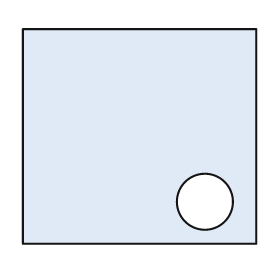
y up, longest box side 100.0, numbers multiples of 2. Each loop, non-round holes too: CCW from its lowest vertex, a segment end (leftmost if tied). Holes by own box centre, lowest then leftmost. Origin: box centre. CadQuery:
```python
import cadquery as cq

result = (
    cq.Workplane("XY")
    .moveTo(-50.0, -46.0)
    .lineTo(50.0, -46.0)
    .lineTo(50.0, 46.0)
    .lineTo(-50.0, 46.0)
    .close()
    .moveTo(28.0, -28.0)
    .circle(12.0)
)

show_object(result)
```